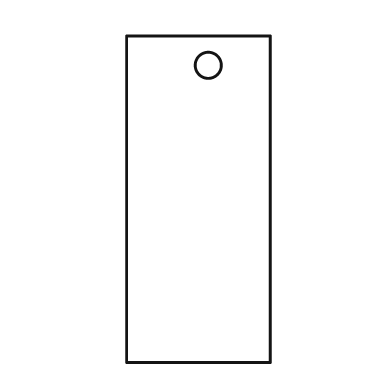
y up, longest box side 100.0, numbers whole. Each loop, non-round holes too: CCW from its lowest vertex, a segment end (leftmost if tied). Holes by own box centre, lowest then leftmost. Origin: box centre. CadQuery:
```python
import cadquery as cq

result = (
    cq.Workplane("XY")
    .moveTo(-22.0, -50.0)
    .lineTo(22.0, -50.0)
    .lineTo(22.0, 50.0)
    .lineTo(-22.0, 50.0)
    .close()
    .moveTo(3.0, 41.0)
    .circle(4.0)
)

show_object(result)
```